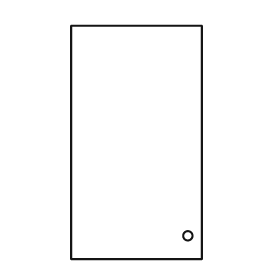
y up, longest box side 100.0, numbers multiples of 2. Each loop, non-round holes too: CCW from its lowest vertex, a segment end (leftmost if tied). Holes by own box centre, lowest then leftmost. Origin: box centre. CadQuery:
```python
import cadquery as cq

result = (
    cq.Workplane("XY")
    .moveTo(-28.0, -50.0)
    .lineTo(28.0, -50.0)
    .lineTo(28.0, 50.0)
    .lineTo(-28.0, 50.0)
    .close()
    .moveTo(22.0, -40.0)
    .circle(2.0)
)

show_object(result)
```